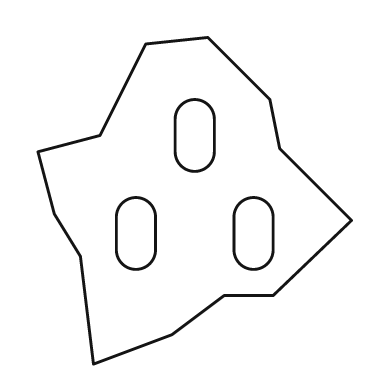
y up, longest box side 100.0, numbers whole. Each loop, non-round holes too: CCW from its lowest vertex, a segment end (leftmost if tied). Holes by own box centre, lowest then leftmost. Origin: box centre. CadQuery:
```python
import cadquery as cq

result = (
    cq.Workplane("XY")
    .moveTo(-31.0, -50.0)
    .lineTo(-7.0, -41.0)
    .lineTo(9.0, -29.0)
    .lineTo(24.0, -29.0)
    .lineTo(48.0, -6.0)
    .lineTo(26.0, 16.0)
    .lineTo(23.0, 31.0)
    .lineTo(4.0, 50.0)
    .lineTo(-15.0, 48.0)
    .lineTo(-29.0, 20.0)
    .lineTo(-48.0, 15.0)
    .lineTo(-43.0, -4.0)
    .lineTo(-35.0, -17.0)
    .close()
    .moveTo(-24.0, -15.0)
    .threePointArc((-18.0, -21.0), (-12.0, -15.0))
    .lineTo(-12.0, -5.0)
    .threePointArc((-18.0, 1.0), (-24.0, -5.0))
    .close()
    .moveTo(12.0, -15.0)
    .threePointArc((18.0, -21.0), (24.0, -15.0))
    .lineTo(24.0, -5.0)
    .threePointArc((18.0, 1.0), (12.0, -5.0))
    .close()
    .moveTo(-6.0, 15.0)
    .threePointArc((0.0, 9.0), (6.0, 15.0))
    .lineTo(6.0, 25.0)
    .threePointArc((0.0, 31.0), (-6.0, 25.0))
    .close()
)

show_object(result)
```